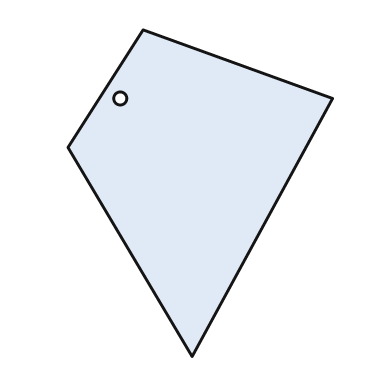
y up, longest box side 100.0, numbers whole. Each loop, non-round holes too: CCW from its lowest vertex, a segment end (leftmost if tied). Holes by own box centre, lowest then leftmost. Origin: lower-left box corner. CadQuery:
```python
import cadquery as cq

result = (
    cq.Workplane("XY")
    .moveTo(38.0, 0.0)
    .lineTo(81.0, 79.0)
    .lineTo(23.0, 100.0)
    .lineTo(0.0, 64.0)
    .close()
    .moveTo(16.0, 79.0)
    .circle(2.0)
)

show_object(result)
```